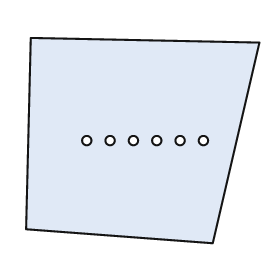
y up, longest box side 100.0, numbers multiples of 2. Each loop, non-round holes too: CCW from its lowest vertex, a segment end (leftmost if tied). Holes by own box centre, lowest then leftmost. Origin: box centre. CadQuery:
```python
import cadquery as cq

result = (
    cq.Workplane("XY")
    .moveTo(30.0, -44.0)
    .lineTo(50.0, 42.0)
    .lineTo(-48.0, 44.0)
    .lineTo(-50.0, -38.0)
    .close()
    .moveTo(-24.0, 0.0)
    .circle(2.0)
    .moveTo(-14.0, 0.0)
    .circle(2.0)
    .moveTo(-4.0, 0.0)
    .circle(2.0)
    .moveTo(6.0, 0.0)
    .circle(2.0)
    .moveTo(16.0, 0.0)
    .circle(2.0)
    .moveTo(26.0, 0.0)
    .circle(2.0)
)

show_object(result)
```